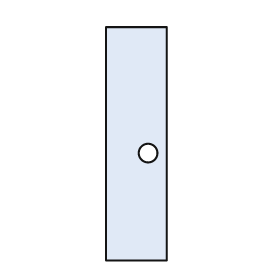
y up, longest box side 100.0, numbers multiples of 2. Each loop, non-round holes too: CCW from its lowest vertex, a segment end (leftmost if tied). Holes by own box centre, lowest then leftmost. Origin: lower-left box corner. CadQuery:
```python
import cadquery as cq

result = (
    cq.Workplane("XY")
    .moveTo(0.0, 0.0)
    .lineTo(26.0, 0.0)
    .lineTo(26.0, 100.0)
    .lineTo(0.0, 100.0)
    .close()
    .moveTo(18.0, 46.0)
    .circle(4.0)
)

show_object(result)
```